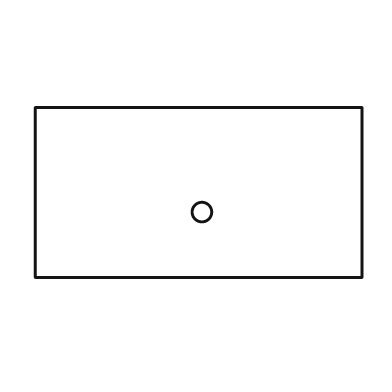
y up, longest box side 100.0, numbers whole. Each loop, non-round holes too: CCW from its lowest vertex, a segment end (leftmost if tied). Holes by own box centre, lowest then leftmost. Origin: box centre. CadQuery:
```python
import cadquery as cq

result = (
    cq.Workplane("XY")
    .moveTo(-50.0, -26.0)
    .lineTo(50.0, -26.0)
    .lineTo(50.0, 26.0)
    .lineTo(-50.0, 26.0)
    .close()
    .moveTo(1.0, -6.0)
    .circle(3.0)
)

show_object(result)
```